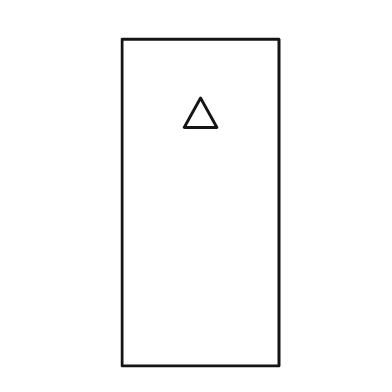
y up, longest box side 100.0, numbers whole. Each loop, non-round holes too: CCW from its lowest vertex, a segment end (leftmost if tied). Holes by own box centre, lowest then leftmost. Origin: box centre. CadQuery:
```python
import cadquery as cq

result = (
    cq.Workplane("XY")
    .moveTo(-24.0, -50.0)
    .lineTo(24.0, -50.0)
    .lineTo(24.0, 50.0)
    .lineTo(-24.0, 50.0)
    .close()
    .moveTo(-5.0, 23.0)
    .lineTo(5.0, 23.0)
    .lineTo(0.0, 32.0)
    .close()
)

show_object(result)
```